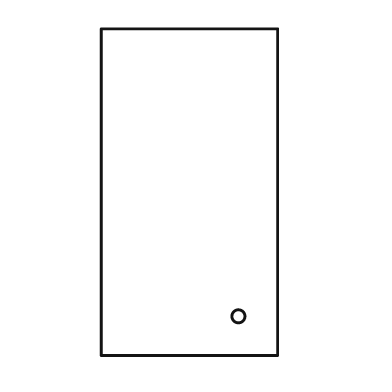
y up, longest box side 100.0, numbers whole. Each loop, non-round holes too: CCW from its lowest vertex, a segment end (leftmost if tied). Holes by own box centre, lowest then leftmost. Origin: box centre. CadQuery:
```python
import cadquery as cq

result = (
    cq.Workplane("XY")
    .moveTo(-27.0, -50.0)
    .lineTo(27.0, -50.0)
    .lineTo(27.0, 50.0)
    .lineTo(-27.0, 50.0)
    .close()
    .moveTo(15.0, -38.0)
    .circle(2.0)
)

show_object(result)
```